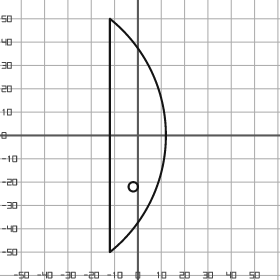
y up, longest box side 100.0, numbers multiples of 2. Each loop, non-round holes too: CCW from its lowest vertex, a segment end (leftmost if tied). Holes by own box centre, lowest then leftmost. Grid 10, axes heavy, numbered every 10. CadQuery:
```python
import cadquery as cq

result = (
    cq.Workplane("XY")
    .moveTo(-12.0, -50.0)
    .threePointArc((12.0, 0.0), (-12.0, 50.0))
    .close()
    .moveTo(-2.0, -22.0)
    .circle(2.0)
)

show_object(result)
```